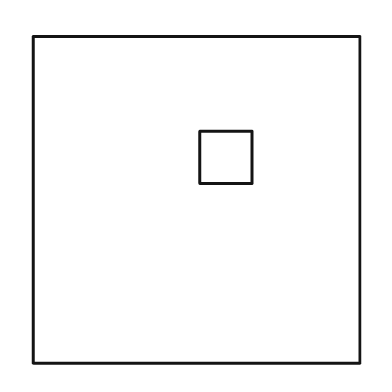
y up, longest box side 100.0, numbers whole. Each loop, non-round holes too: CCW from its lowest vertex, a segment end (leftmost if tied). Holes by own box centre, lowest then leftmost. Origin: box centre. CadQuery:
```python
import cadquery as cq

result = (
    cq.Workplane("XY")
    .moveTo(-50.0, -50.0)
    .lineTo(50.0, -50.0)
    .lineTo(50.0, 50.0)
    .lineTo(-50.0, 50.0)
    .close()
    .moveTo(1.0, 5.0)
    .lineTo(17.0, 5.0)
    .lineTo(17.0, 21.0)
    .lineTo(1.0, 21.0)
    .close()
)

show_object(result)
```